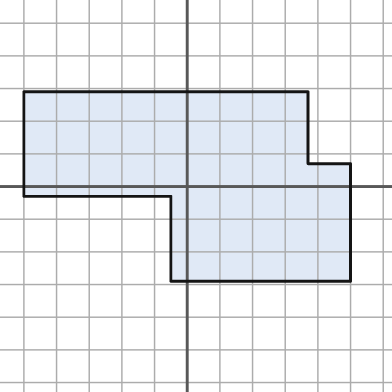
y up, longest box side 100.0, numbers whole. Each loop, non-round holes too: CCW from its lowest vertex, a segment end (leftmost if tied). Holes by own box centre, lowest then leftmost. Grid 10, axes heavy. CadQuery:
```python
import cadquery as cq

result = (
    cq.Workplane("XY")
    .moveTo(-5.0, -29.0)
    .lineTo(50.0, -29.0)
    .lineTo(50.0, 7.0)
    .lineTo(37.0, 7.0)
    .lineTo(37.0, 29.0)
    .lineTo(-50.0, 29.0)
    .lineTo(-50.0, -3.0)
    .lineTo(-5.0, -3.0)
    .close()
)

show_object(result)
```